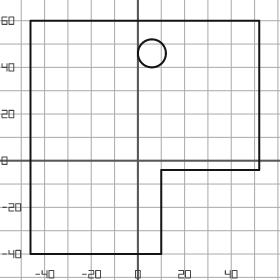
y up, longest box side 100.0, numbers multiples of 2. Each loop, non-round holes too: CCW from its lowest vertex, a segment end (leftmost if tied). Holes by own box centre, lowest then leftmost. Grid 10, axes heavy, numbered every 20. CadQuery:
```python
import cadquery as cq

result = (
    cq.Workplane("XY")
    .moveTo(-46.0, -40.0)
    .lineTo(10.0, -40.0)
    .lineTo(10.0, -4.0)
    .lineTo(52.0, -4.0)
    .lineTo(52.0, 60.0)
    .lineTo(-46.0, 60.0)
    .close()
    .moveTo(6.0, 46.0)
    .circle(6.0)
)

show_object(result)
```